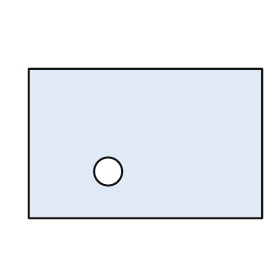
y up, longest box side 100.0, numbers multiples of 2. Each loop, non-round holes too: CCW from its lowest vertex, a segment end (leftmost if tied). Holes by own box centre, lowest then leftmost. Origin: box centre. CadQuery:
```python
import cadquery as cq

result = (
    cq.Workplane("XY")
    .moveTo(-50.0, -32.0)
    .lineTo(50.0, -32.0)
    .lineTo(50.0, 32.0)
    .lineTo(-50.0, 32.0)
    .close()
    .moveTo(-16.0, -12.0)
    .circle(6.0)
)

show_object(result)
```